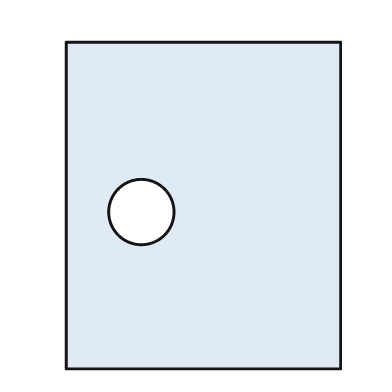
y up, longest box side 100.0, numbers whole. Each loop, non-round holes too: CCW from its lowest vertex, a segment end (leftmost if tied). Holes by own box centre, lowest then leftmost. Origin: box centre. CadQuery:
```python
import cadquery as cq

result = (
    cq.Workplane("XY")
    .moveTo(-42.0, -50.0)
    .lineTo(42.0, -50.0)
    .lineTo(42.0, 50.0)
    .lineTo(-42.0, 50.0)
    .close()
    .moveTo(-19.0, -2.0)
    .circle(10.0)
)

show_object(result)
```